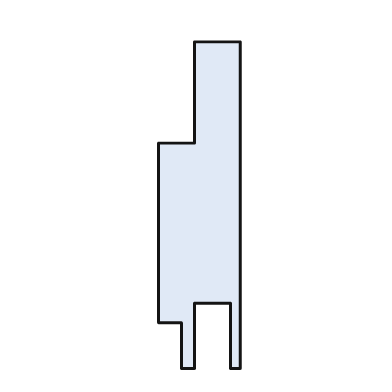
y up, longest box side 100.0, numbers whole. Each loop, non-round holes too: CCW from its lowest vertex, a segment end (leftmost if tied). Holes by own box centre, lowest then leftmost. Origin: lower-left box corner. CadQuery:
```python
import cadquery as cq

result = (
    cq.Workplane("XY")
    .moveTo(7.0, 0.0)
    .lineTo(11.0, 0.0)
    .lineTo(11.0, 20.0)
    .lineTo(22.0, 20.0)
    .lineTo(22.0, 0.0)
    .lineTo(25.0, 0.0)
    .lineTo(25.0, 100.0)
    .lineTo(11.0, 100.0)
    .lineTo(11.0, 69.0)
    .lineTo(0.0, 69.0)
    .lineTo(0.0, 14.0)
    .lineTo(7.0, 14.0)
    .close()
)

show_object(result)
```